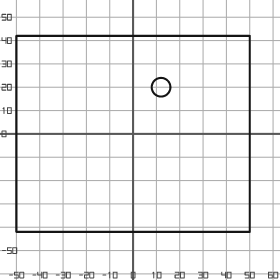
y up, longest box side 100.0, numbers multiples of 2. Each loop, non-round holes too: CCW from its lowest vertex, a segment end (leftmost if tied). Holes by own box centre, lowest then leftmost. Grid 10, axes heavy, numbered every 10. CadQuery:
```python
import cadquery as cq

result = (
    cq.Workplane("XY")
    .moveTo(-50.0, -42.0)
    .lineTo(50.0, -42.0)
    .lineTo(50.0, 42.0)
    .lineTo(-50.0, 42.0)
    .close()
    .moveTo(12.0, 20.0)
    .circle(4.0)
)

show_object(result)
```